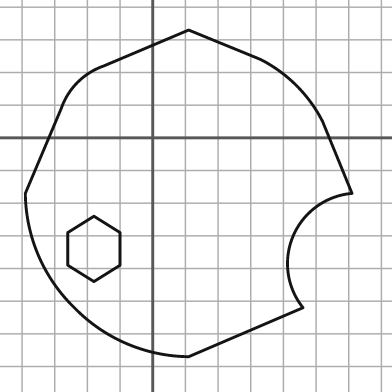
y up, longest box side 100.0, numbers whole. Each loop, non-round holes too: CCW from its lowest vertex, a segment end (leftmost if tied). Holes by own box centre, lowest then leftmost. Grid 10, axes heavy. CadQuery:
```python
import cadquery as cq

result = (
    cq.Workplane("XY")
    .moveTo(11.0, -67.0)
    .lineTo(46.0, -52.0)
    .threePointArc((43.0, -30.0), (61.0, -17.0))
    .lineTo(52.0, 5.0)
    .threePointArc((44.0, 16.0), (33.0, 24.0))
    .lineTo(11.0, 33.0)
    .lineTo(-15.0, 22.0)
    .threePointArc((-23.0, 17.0), (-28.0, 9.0))
    .lineTo(-39.0, -17.0)
    .threePointArc((-35.0, -36.0), (-24.0, -52.0))
    .threePointArc((-8.0, -63.0), (11.0, -67.0))
    .close()
    .moveTo(-18.0, -44.0)
    .lineTo(-10.0, -39.0)
    .lineTo(-10.0, -29.0)
    .lineTo(-18.0, -24.0)
    .lineTo(-26.0, -29.0)
    .lineTo(-26.0, -39.0)
    .close()
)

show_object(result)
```